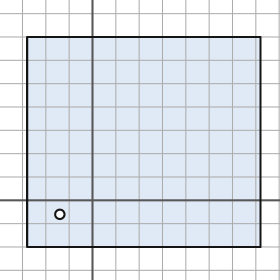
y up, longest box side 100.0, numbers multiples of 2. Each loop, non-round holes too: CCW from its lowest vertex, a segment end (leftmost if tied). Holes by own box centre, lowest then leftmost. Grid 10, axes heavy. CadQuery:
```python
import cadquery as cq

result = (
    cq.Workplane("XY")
    .moveTo(-28.0, -20.0)
    .lineTo(72.0, -20.0)
    .lineTo(72.0, 70.0)
    .lineTo(-28.0, 70.0)
    .close()
    .moveTo(-14.0, -6.0)
    .circle(2.0)
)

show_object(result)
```